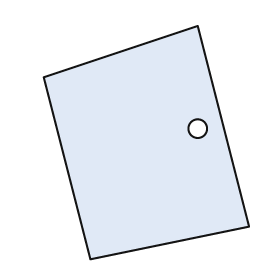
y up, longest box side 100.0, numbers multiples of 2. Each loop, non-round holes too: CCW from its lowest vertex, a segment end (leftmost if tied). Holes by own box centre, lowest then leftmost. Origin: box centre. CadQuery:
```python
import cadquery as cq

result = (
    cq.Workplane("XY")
    .moveTo(-24.0, -50.0)
    .lineTo(44.0, -36.0)
    .lineTo(22.0, 50.0)
    .lineTo(-44.0, 28.0)
    .close()
    .moveTo(22.0, 6.0)
    .circle(4.0)
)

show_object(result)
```